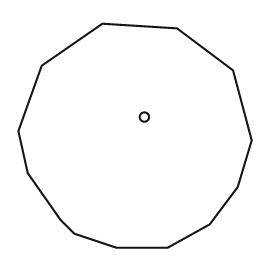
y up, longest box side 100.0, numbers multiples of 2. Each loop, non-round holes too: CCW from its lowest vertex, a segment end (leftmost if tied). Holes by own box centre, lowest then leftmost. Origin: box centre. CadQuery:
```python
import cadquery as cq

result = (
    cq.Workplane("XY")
    .moveTo(-8.0, -48.0)
    .lineTo(14.0, -48.0)
    .lineTo(32.0, -38.0)
    .lineTo(44.0, -22.0)
    .lineTo(50.0, -2.0)
    .lineTo(42.0, 28.0)
    .lineTo(18.0, 46.0)
    .lineTo(-14.0, 48.0)
    .lineTo(-40.0, 30.0)
    .lineTo(-50.0, 2.0)
    .lineTo(-46.0, -16.0)
    .lineTo(-32.0, -36.0)
    .lineTo(-26.0, -42.0)
    .close()
    .moveTo(4.0, 8.0)
    .circle(2.0)
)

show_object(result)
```